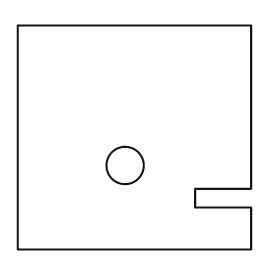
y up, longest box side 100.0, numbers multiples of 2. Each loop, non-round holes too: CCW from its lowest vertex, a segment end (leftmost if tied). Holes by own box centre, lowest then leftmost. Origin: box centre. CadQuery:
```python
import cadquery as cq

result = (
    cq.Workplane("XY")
    .moveTo(-50.0, -48.0)
    .lineTo(50.0, -48.0)
    .lineTo(50.0, -30.0)
    .lineTo(26.0, -30.0)
    .lineTo(26.0, -22.0)
    .lineTo(50.0, -22.0)
    .lineTo(50.0, 48.0)
    .lineTo(-50.0, 48.0)
    .close()
    .moveTo(-4.0, -12.0)
    .circle(8.0)
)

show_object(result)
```